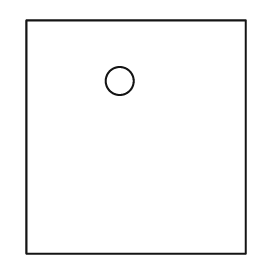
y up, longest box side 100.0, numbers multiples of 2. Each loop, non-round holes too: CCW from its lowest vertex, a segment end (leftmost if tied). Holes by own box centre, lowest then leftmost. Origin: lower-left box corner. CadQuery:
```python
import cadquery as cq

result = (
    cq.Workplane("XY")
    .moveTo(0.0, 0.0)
    .lineTo(94.0, 0.0)
    .lineTo(94.0, 100.0)
    .lineTo(0.0, 100.0)
    .close()
    .moveTo(40.0, 74.0)
    .circle(6.0)
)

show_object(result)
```